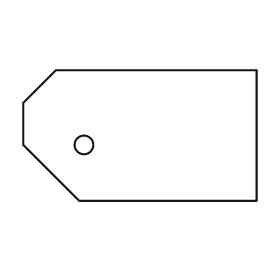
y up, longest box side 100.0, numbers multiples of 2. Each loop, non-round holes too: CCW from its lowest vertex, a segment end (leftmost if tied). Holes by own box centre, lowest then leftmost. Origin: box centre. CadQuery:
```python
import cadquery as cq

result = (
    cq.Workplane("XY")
    .moveTo(-26.0, -28.0)
    .lineTo(50.0, -28.0)
    .lineTo(50.0, 28.0)
    .lineTo(-36.0, 28.0)
    .lineTo(-50.0, 14.0)
    .lineTo(-50.0, -4.0)
    .close()
    .moveTo(-24.0, -4.0)
    .circle(4.0)
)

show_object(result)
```